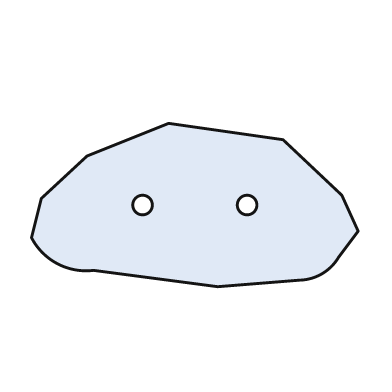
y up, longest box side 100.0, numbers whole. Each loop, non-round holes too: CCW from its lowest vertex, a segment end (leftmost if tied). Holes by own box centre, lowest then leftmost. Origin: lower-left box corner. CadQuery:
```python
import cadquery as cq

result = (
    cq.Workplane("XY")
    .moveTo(57.0, 0.0)
    .lineTo(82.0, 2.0)
    .threePointArc((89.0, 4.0), (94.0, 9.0))
    .lineTo(100.0, 17.0)
    .lineTo(95.0, 28.0)
    .lineTo(77.0, 45.0)
    .lineTo(42.0, 50.0)
    .lineTo(17.0, 40.0)
    .lineTo(3.0, 27.0)
    .lineTo(0.0, 15.0)
    .threePointArc((8.0, 7.0), (19.0, 5.0))
    .close()
    .moveTo(34.0, 25.0)
    .circle(3.0)
    .moveTo(66.0, 25.0)
    .circle(3.0)
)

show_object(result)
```